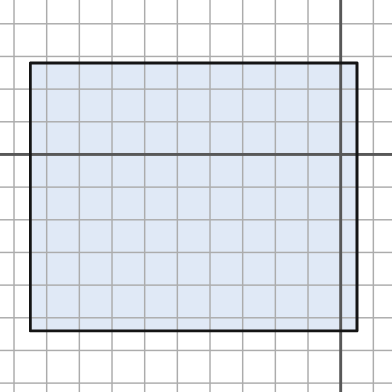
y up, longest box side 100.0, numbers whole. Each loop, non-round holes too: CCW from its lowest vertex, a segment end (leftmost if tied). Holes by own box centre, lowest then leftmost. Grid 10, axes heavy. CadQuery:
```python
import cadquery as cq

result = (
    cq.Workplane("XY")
    .moveTo(-95.0, -54.0)
    .lineTo(5.0, -54.0)
    .lineTo(5.0, 28.0)
    .lineTo(-95.0, 28.0)
    .close()
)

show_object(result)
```